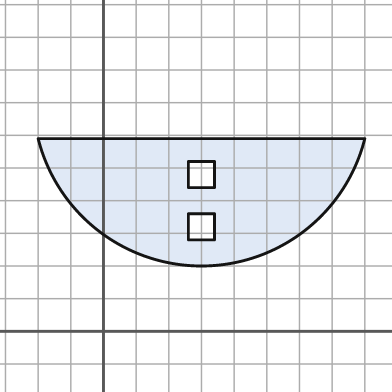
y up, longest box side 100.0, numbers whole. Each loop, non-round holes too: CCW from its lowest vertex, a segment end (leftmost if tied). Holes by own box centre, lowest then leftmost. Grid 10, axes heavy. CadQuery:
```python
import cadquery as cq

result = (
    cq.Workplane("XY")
    .moveTo(-20.0, 59.0)
    .threePointArc((30.0, 20.0), (80.0, 59.0))
    .close()
    .moveTo(26.0, 28.0)
    .lineTo(34.0, 28.0)
    .lineTo(34.0, 36.0)
    .lineTo(26.0, 36.0)
    .close()
    .moveTo(26.0, 44.0)
    .lineTo(34.0, 44.0)
    .lineTo(34.0, 52.0)
    .lineTo(26.0, 52.0)
    .close()
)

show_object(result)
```